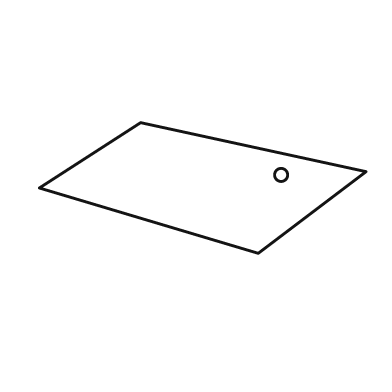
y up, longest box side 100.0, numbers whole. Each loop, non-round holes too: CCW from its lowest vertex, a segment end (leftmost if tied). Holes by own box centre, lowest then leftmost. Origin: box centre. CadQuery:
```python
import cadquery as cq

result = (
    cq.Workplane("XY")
    .moveTo(17.0, -20.0)
    .lineTo(50.0, 5.0)
    .lineTo(-19.0, 20.0)
    .lineTo(-50.0, 0.0)
    .close()
    .moveTo(24.0, 4.0)
    .circle(2.0)
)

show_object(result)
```